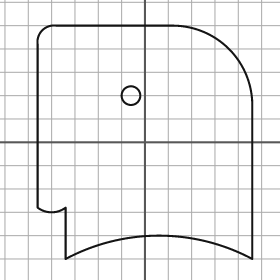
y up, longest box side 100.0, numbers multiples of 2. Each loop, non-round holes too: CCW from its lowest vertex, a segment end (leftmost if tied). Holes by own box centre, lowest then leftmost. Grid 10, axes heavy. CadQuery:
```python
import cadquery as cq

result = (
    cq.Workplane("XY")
    .moveTo(-34.0, -50.0)
    .threePointArc((6.0, -40.0), (46.0, -50.0))
    .lineTo(46.0, 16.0)
    .threePointArc((36.0, 40.0), (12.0, 50.0))
    .lineTo(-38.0, 50.0)
    .threePointArc((-44.0, 48.0), (-46.0, 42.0))
    .lineTo(-46.0, -28.0)
    .threePointArc((-40.0, -30.0), (-34.0, -28.0))
    .close()
    .moveTo(-6.0, 20.0)
    .circle(4.0)
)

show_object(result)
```